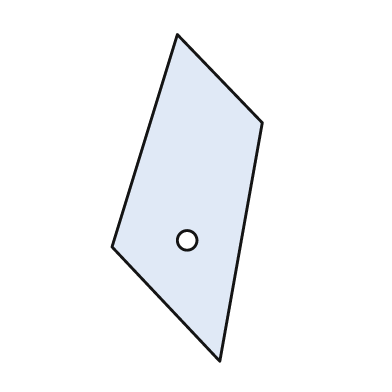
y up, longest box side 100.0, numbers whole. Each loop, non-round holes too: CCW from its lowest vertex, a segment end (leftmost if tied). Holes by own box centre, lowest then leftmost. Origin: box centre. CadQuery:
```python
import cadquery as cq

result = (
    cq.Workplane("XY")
    .moveTo(10.0, -50.0)
    .lineTo(23.0, 23.0)
    .lineTo(-3.0, 50.0)
    .lineTo(-23.0, -15.0)
    .close()
    .moveTo(0.0, -13.0)
    .circle(3.0)
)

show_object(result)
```